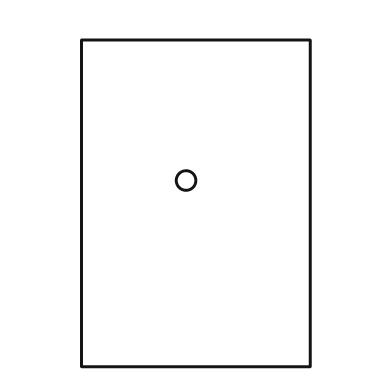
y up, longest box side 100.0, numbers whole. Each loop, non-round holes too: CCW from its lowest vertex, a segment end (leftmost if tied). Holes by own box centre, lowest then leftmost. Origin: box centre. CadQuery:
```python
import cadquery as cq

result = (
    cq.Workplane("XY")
    .moveTo(-35.0, -50.0)
    .lineTo(35.0, -50.0)
    .lineTo(35.0, 50.0)
    .lineTo(-35.0, 50.0)
    .close()
    .moveTo(-3.0, 7.0)
    .circle(3.0)
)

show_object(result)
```